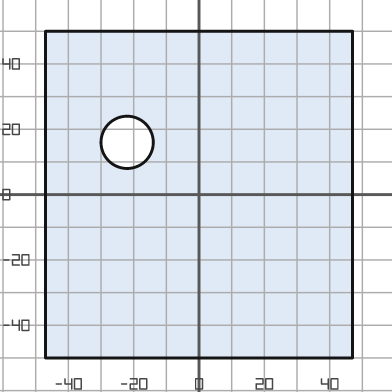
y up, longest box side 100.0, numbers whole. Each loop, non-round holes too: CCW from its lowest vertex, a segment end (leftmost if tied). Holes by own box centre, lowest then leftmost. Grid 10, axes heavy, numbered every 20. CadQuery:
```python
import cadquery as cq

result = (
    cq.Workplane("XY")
    .moveTo(-47.0, -50.0)
    .lineTo(47.0, -50.0)
    .lineTo(47.0, 50.0)
    .lineTo(-47.0, 50.0)
    .close()
    .moveTo(-22.0, 16.0)
    .circle(8.0)
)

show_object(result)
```